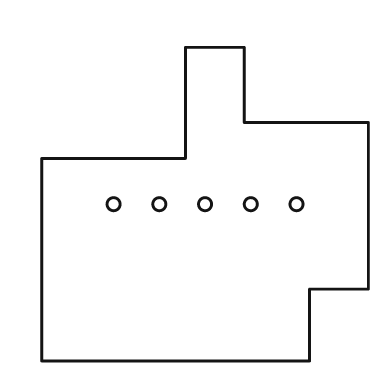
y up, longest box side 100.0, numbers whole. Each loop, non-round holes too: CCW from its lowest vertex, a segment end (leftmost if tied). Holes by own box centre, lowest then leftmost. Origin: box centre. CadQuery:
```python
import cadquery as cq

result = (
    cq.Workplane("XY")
    .moveTo(-50.0, -48.0)
    .lineTo(32.0, -48.0)
    .lineTo(32.0, -26.0)
    .lineTo(50.0, -26.0)
    .lineTo(50.0, 25.0)
    .lineTo(12.0, 25.0)
    .lineTo(12.0, 48.0)
    .lineTo(-6.0, 48.0)
    .lineTo(-6.0, 14.0)
    .lineTo(-50.0, 14.0)
    .close()
    .moveTo(-28.0, 0.0)
    .circle(2.0)
    .moveTo(-14.0, 0.0)
    .circle(2.0)
    .moveTo(0.0, 0.0)
    .circle(2.0)
    .moveTo(14.0, 0.0)
    .circle(2.0)
    .moveTo(28.0, 0.0)
    .circle(2.0)
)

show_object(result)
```